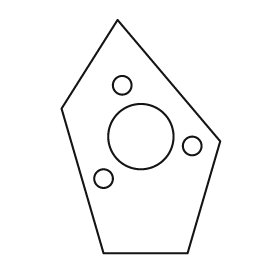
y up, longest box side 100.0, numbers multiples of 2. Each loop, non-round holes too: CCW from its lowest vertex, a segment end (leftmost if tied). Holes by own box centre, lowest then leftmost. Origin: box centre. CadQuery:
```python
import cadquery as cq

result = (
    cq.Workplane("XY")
    .moveTo(-16.0, -50.0)
    .lineTo(20.0, -50.0)
    .lineTo(34.0, -2.0)
    .lineTo(-10.0, 50.0)
    .lineTo(-34.0, 12.0)
    .close()
    .moveTo(-16.0, -18.0)
    .circle(4.0)
    .moveTo(22.0, -4.0)
    .circle(4.0)
    .moveTo(0.0, 0.0)
    .circle(14.0)
    .moveTo(-8.0, 22.0)
    .circle(4.0)
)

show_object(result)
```